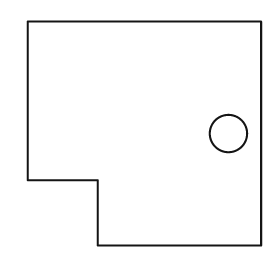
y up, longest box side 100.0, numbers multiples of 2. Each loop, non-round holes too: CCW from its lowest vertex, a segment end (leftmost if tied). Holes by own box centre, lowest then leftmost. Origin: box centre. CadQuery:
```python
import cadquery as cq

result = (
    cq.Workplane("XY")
    .moveTo(-20.0, -48.0)
    .lineTo(50.0, -48.0)
    .lineTo(50.0, 48.0)
    .lineTo(-50.0, 48.0)
    .lineTo(-50.0, -20.0)
    .lineTo(-20.0, -20.0)
    .close()
    .moveTo(36.0, 0.0)
    .circle(8.0)
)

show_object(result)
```